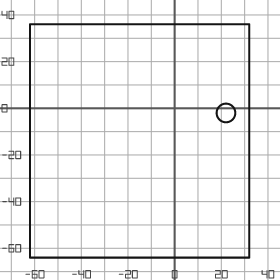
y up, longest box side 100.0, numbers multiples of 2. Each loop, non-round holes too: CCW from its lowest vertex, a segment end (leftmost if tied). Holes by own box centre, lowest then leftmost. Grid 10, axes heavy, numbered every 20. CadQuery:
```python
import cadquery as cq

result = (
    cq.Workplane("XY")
    .moveTo(-62.0, -64.0)
    .lineTo(32.0, -64.0)
    .lineTo(32.0, 36.0)
    .lineTo(-62.0, 36.0)
    .close()
    .moveTo(22.0, -2.0)
    .circle(4.0)
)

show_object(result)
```